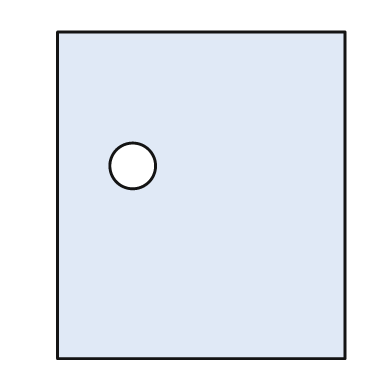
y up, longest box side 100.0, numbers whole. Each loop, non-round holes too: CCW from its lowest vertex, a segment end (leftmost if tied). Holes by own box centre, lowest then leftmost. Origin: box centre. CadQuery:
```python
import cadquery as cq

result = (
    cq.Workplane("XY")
    .moveTo(-44.0, -50.0)
    .lineTo(44.0, -50.0)
    .lineTo(44.0, 50.0)
    .lineTo(-44.0, 50.0)
    .close()
    .moveTo(-21.0, 9.0)
    .circle(7.0)
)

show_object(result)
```